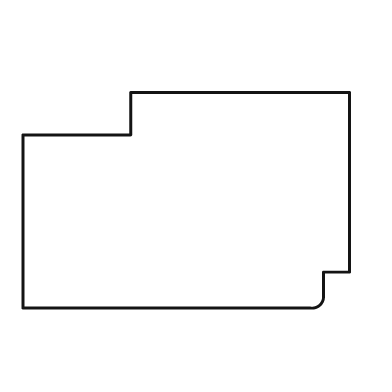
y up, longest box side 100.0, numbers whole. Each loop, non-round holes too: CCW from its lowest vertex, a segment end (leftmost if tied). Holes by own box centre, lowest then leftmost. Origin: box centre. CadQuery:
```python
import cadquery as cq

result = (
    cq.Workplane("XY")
    .moveTo(-50.0, -33.0)
    .lineTo(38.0, -33.0)
    .threePointArc((41.0, -32.0), (42.0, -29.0))
    .lineTo(42.0, -22.0)
    .lineTo(50.0, -22.0)
    .lineTo(50.0, 33.0)
    .lineTo(-17.0, 33.0)
    .lineTo(-17.0, 20.0)
    .lineTo(-50.0, 20.0)
    .close()
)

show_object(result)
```